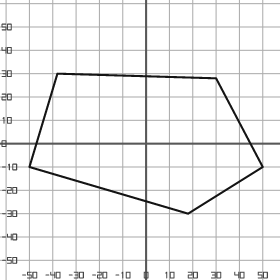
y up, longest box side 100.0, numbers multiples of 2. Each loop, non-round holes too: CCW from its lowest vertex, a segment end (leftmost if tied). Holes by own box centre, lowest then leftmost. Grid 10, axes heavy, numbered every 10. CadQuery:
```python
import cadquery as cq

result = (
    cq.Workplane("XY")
    .moveTo(18.0, -30.0)
    .lineTo(50.0, -10.0)
    .lineTo(30.0, 28.0)
    .lineTo(-38.0, 30.0)
    .lineTo(-50.0, -10.0)
    .close()
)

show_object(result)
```